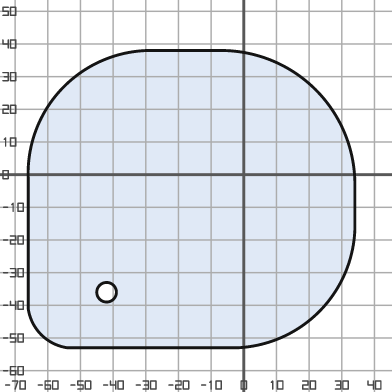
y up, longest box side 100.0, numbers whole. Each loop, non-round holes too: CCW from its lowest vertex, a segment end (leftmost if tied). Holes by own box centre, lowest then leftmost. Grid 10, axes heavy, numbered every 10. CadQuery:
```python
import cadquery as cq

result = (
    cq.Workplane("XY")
    .moveTo(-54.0, -53.0)
    .lineTo(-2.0, -53.0)
    .threePointArc((23.0, -42.0), (34.0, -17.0))
    .lineTo(34.0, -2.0)
    .threePointArc((22.0, 26.0), (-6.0, 38.0))
    .lineTo(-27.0, 38.0)
    .threePointArc((-55.0, 27.0), (-66.0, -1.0))
    .lineTo(-66.0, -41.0)
    .threePointArc((-62.0, -49.0), (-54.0, -53.0))
    .close()
    .moveTo(-42.0, -36.0)
    .circle(3.0)
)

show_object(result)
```